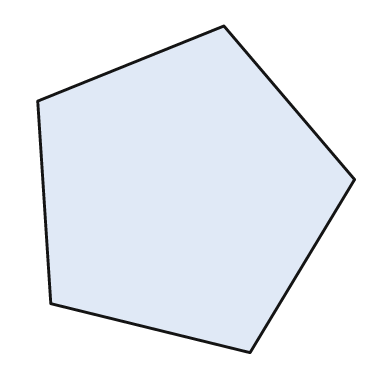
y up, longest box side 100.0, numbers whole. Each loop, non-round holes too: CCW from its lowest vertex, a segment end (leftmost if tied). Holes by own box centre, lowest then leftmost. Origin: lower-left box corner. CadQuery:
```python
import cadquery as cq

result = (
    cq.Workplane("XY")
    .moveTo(65.0, 0.0)
    .lineTo(97.0, 53.0)
    .lineTo(57.0, 100.0)
    .lineTo(0.0, 77.0)
    .lineTo(4.0, 15.0)
    .close()
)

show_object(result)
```